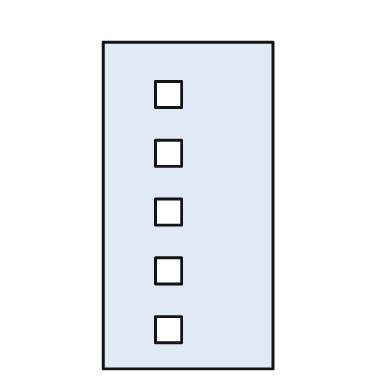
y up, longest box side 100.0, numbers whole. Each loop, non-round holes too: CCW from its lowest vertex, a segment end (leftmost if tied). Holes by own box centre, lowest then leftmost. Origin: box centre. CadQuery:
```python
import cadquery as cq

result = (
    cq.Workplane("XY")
    .moveTo(-26.0, -50.0)
    .lineTo(26.0, -50.0)
    .lineTo(26.0, 50.0)
    .lineTo(-26.0, 50.0)
    .close()
    .moveTo(-10.0, -42.0)
    .lineTo(-2.0, -42.0)
    .lineTo(-2.0, -34.0)
    .lineTo(-10.0, -34.0)
    .close()
    .moveTo(-10.0, -24.0)
    .lineTo(-2.0, -24.0)
    .lineTo(-2.0, -16.0)
    .lineTo(-10.0, -16.0)
    .close()
    .moveTo(-10.0, -6.0)
    .lineTo(-2.0, -6.0)
    .lineTo(-2.0, 2.0)
    .lineTo(-10.0, 2.0)
    .close()
    .moveTo(-10.0, 12.0)
    .lineTo(-2.0, 12.0)
    .lineTo(-2.0, 20.0)
    .lineTo(-10.0, 20.0)
    .close()
    .moveTo(-10.0, 30.0)
    .lineTo(-2.0, 30.0)
    .lineTo(-2.0, 38.0)
    .lineTo(-10.0, 38.0)
    .close()
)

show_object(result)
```